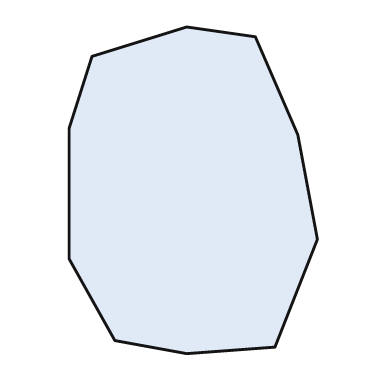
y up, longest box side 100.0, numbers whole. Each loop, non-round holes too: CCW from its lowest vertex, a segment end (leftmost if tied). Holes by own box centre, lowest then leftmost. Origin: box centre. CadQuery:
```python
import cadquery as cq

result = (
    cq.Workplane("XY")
    .moveTo(-2.0, -50.0)
    .lineTo(25.0, -48.0)
    .lineTo(38.0, -15.0)
    .lineTo(32.0, 17.0)
    .lineTo(19.0, 47.0)
    .lineTo(-2.0, 50.0)
    .lineTo(-31.0, 41.0)
    .lineTo(-38.0, 19.0)
    .lineTo(-38.0, -21.0)
    .lineTo(-24.0, -46.0)
    .close()
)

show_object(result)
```